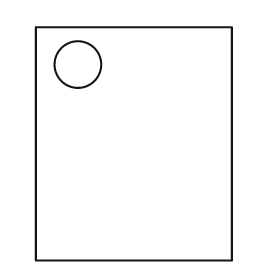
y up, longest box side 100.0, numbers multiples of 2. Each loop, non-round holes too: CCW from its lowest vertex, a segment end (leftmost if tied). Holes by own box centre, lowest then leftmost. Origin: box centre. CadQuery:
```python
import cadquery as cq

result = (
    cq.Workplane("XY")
    .moveTo(-42.0, -50.0)
    .lineTo(42.0, -50.0)
    .lineTo(42.0, 50.0)
    .lineTo(-42.0, 50.0)
    .close()
    .moveTo(-24.0, 34.0)
    .circle(10.0)
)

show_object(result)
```